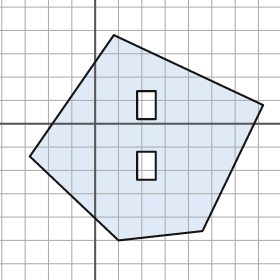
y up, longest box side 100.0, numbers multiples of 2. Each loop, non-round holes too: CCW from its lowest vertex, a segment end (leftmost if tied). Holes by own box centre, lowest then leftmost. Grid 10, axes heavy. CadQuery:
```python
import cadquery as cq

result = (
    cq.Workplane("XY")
    .moveTo(10.0, -50.0)
    .lineTo(46.0, -46.0)
    .lineTo(72.0, 8.0)
    .lineTo(8.0, 38.0)
    .lineTo(-28.0, -14.0)
    .close()
    .moveTo(18.0, -24.0)
    .lineTo(26.0, -24.0)
    .lineTo(26.0, -12.0)
    .lineTo(18.0, -12.0)
    .close()
    .moveTo(18.0, 2.0)
    .lineTo(26.0, 2.0)
    .lineTo(26.0, 14.0)
    .lineTo(18.0, 14.0)
    .close()
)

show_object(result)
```